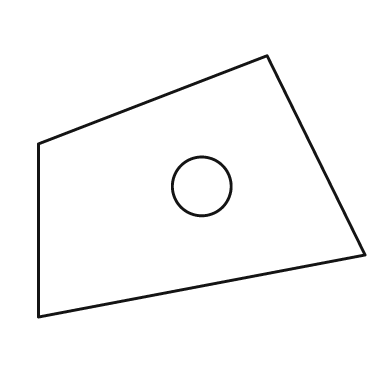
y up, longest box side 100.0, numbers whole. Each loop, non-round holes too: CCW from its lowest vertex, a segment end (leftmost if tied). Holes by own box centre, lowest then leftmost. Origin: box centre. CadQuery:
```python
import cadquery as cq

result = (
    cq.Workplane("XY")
    .moveTo(-50.0, -40.0)
    .lineTo(50.0, -21.0)
    .lineTo(20.0, 40.0)
    .lineTo(-50.0, 13.0)
    .close()
    .moveTo(0.0, 0.0)
    .circle(9.0)
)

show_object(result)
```